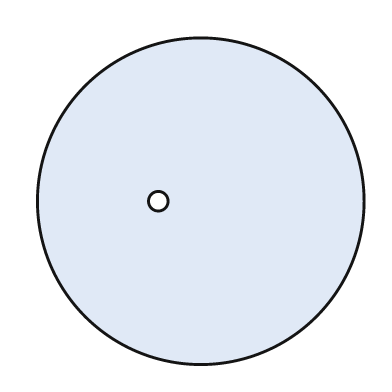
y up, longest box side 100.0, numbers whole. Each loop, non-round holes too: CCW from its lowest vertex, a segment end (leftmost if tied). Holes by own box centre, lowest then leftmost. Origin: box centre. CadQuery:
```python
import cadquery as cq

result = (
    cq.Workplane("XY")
    .moveTo(0.0, 0.0)
    .circle(50.0)
    .moveTo(-13.0, 0.0)
    .circle(3.0)
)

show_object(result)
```